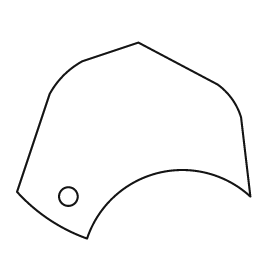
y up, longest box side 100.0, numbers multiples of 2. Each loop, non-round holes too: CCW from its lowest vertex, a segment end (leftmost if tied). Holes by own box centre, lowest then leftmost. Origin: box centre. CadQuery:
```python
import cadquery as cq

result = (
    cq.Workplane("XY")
    .moveTo(-20.0, -42.0)
    .threePointArc((10.0, -14.0), (50.0, -24.0))
    .lineTo(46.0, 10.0)
    .threePointArc((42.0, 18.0), (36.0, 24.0))
    .lineTo(2.0, 42.0)
    .lineTo(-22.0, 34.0)
    .threePointArc((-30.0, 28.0), (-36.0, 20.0))
    .lineTo(-50.0, -22.0)
    .threePointArc((-36.0, -34.0), (-20.0, -42.0))
    .close()
    .moveTo(-28.0, -24.0)
    .circle(4.0)
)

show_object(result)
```